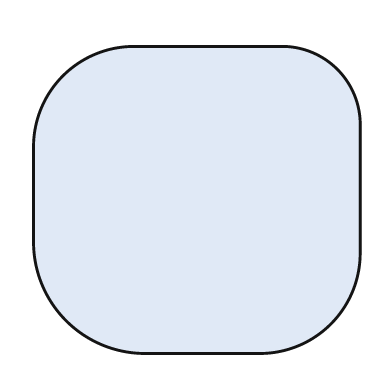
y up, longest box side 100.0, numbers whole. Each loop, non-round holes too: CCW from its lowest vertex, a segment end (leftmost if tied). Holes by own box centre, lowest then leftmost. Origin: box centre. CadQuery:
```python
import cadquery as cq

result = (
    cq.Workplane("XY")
    .moveTo(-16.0, -47.0)
    .lineTo(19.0, -47.0)
    .threePointArc((41.0, -38.0), (50.0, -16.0))
    .lineTo(50.0, 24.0)
    .threePointArc((43.0, 40.0), (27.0, 47.0))
    .lineTo(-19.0, 47.0)
    .threePointArc((-41.0, 38.0), (-50.0, 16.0))
    .lineTo(-50.0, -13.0)
    .threePointArc((-40.0, -37.0), (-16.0, -47.0))
    .close()
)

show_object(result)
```